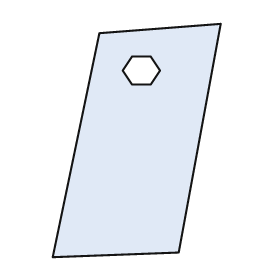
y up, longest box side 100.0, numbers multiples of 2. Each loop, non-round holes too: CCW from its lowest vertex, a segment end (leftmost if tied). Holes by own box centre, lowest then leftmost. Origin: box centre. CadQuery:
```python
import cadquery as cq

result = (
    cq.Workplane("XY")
    .moveTo(-36.0, -50.0)
    .lineTo(18.0, -48.0)
    .lineTo(36.0, 50.0)
    .lineTo(-16.0, 46.0)
    .close()
    .moveTo(-2.0, 24.0)
    .lineTo(6.0, 24.0)
    .lineTo(10.0, 30.0)
    .lineTo(6.0, 36.0)
    .lineTo(-2.0, 36.0)
    .lineTo(-6.0, 30.0)
    .close()
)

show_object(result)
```